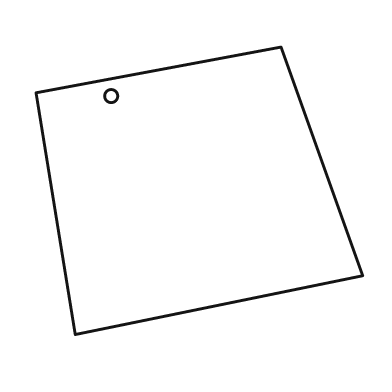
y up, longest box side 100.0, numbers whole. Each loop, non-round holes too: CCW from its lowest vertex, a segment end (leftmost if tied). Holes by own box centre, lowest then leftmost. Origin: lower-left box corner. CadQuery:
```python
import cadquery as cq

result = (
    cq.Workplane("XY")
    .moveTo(12.0, 0.0)
    .lineTo(100.0, 18.0)
    .lineTo(75.0, 88.0)
    .lineTo(0.0, 74.0)
    .close()
    .moveTo(23.0, 73.0)
    .circle(2.0)
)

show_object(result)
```